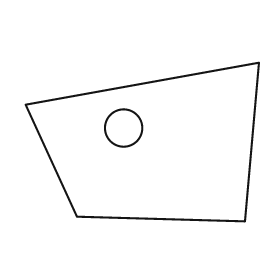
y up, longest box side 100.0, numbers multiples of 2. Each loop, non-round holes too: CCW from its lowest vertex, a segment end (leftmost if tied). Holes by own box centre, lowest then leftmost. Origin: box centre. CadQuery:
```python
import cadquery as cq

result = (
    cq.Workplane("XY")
    .moveTo(44.0, -34.0)
    .lineTo(50.0, 34.0)
    .lineTo(-50.0, 16.0)
    .lineTo(-28.0, -32.0)
    .close()
    .moveTo(-8.0, 6.0)
    .circle(8.0)
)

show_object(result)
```